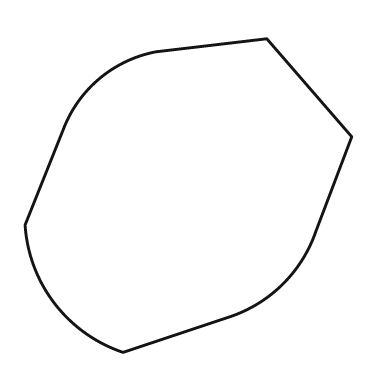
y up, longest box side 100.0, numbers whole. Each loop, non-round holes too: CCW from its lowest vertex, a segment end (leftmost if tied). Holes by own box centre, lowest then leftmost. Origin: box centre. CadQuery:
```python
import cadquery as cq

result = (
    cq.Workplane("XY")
    .moveTo(-20.0, -48.0)
    .lineTo(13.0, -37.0)
    .threePointArc((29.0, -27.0), (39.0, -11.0))
    .lineTo(50.0, 18.0)
    .lineTo(24.0, 48.0)
    .lineTo(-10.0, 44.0)
    .threePointArc((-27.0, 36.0), (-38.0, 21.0))
    .lineTo(-50.0, -9.0)
    .threePointArc((-41.0, -33.0), (-20.0, -48.0))
    .close()
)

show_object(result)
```